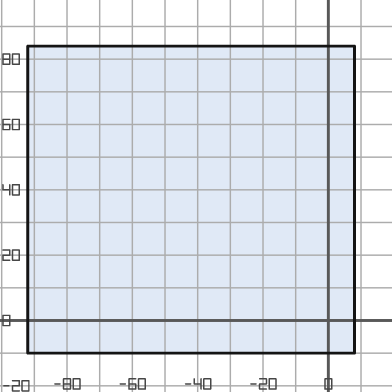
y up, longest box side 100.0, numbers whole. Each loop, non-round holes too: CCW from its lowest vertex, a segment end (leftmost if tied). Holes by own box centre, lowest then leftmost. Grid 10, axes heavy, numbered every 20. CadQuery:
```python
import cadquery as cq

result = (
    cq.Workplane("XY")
    .moveTo(-92.0, -10.0)
    .lineTo(8.0, -10.0)
    .lineTo(8.0, 84.0)
    .lineTo(-92.0, 84.0)
    .close()
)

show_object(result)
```